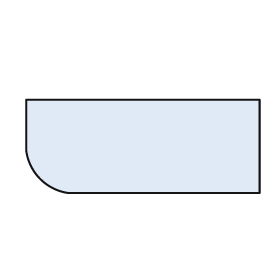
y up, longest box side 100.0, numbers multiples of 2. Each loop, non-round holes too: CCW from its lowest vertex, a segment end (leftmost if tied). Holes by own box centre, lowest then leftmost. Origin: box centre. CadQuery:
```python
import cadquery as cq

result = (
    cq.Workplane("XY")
    .moveTo(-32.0, -20.0)
    .lineTo(50.0, -20.0)
    .lineTo(50.0, 20.0)
    .lineTo(-50.0, 20.0)
    .lineTo(-50.0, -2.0)
    .threePointArc((-44.0, -14.0), (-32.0, -20.0))
    .close()
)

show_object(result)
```